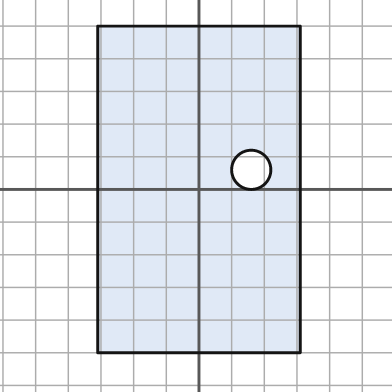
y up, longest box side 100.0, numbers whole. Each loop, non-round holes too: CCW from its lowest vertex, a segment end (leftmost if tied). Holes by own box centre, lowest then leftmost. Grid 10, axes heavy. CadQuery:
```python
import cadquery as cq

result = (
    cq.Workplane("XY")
    .moveTo(-31.0, -50.0)
    .lineTo(31.0, -50.0)
    .lineTo(31.0, 50.0)
    .lineTo(-31.0, 50.0)
    .close()
    .moveTo(16.0, 6.0)
    .circle(6.0)
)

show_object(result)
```